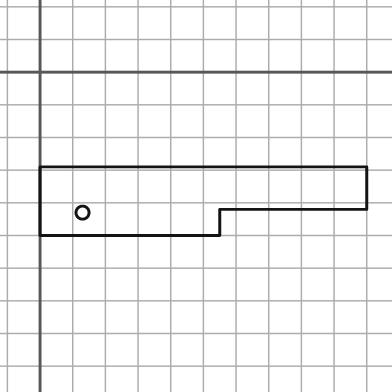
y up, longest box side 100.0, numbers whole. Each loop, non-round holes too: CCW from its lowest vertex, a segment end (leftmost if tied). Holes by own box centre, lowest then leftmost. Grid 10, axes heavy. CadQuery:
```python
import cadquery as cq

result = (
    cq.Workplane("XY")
    .moveTo(0.0, -50.0)
    .lineTo(55.0, -50.0)
    .lineTo(55.0, -42.0)
    .lineTo(100.0, -42.0)
    .lineTo(100.0, -29.0)
    .lineTo(0.0, -29.0)
    .close()
    .moveTo(13.0, -43.0)
    .circle(2.0)
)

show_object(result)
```